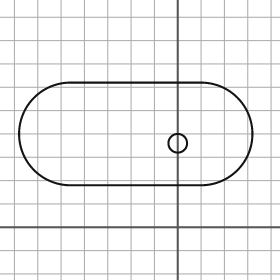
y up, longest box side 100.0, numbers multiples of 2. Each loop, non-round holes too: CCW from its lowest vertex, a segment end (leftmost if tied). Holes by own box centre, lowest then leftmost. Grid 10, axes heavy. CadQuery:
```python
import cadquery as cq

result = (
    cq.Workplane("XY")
    .moveTo(-46.0, 18.0)
    .lineTo(10.0, 18.0)
    .threePointArc((32.0, 40.0), (10.0, 62.0))
    .lineTo(-46.0, 62.0)
    .threePointArc((-68.0, 40.0), (-46.0, 18.0))
    .close()
    .moveTo(0.0, 36.0)
    .circle(4.0)
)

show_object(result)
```